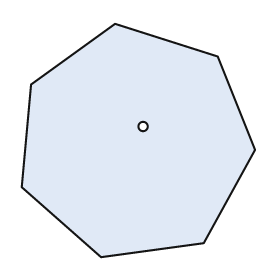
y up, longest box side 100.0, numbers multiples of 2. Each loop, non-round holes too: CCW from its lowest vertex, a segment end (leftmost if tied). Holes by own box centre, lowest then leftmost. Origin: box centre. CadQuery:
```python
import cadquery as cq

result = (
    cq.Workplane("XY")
    .moveTo(-16.0, -50.0)
    .lineTo(28.0, -44.0)
    .lineTo(50.0, -4.0)
    .lineTo(34.0, 36.0)
    .lineTo(-10.0, 50.0)
    .lineTo(-46.0, 24.0)
    .lineTo(-50.0, -20.0)
    .close()
    .moveTo(2.0, 6.0)
    .circle(2.0)
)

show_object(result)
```